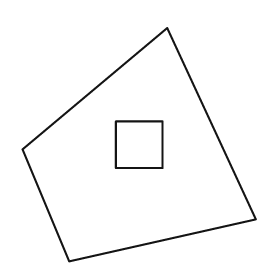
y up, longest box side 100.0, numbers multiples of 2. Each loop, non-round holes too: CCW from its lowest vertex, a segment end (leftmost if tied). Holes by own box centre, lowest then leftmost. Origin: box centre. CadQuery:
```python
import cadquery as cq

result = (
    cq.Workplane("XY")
    .moveTo(-30.0, -50.0)
    .lineTo(50.0, -32.0)
    .lineTo(12.0, 50.0)
    .lineTo(-50.0, -2.0)
    .close()
    .moveTo(-10.0, -10.0)
    .lineTo(10.0, -10.0)
    .lineTo(10.0, 10.0)
    .lineTo(-10.0, 10.0)
    .close()
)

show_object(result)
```